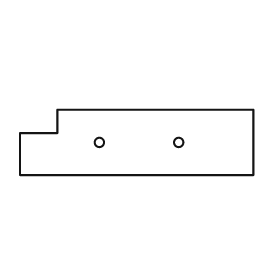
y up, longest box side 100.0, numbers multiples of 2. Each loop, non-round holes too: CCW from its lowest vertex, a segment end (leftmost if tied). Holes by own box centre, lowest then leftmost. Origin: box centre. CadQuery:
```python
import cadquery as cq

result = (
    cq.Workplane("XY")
    .moveTo(-50.0, -14.0)
    .lineTo(50.0, -14.0)
    .lineTo(50.0, 14.0)
    .lineTo(-34.0, 14.0)
    .lineTo(-34.0, 4.0)
    .lineTo(-50.0, 4.0)
    .close()
    .moveTo(-16.0, 0.0)
    .circle(2.0)
    .moveTo(18.0, 0.0)
    .circle(2.0)
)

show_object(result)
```